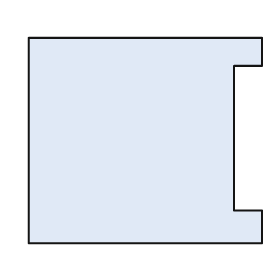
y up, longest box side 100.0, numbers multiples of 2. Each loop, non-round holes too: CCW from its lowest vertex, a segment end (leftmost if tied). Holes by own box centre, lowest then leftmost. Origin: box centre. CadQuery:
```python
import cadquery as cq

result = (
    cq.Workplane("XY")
    .moveTo(-50.0, -44.0)
    .lineTo(50.0, -44.0)
    .lineTo(50.0, -30.0)
    .lineTo(38.0, -30.0)
    .lineTo(38.0, 32.0)
    .lineTo(50.0, 32.0)
    .lineTo(50.0, 44.0)
    .lineTo(-50.0, 44.0)
    .close()
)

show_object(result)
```